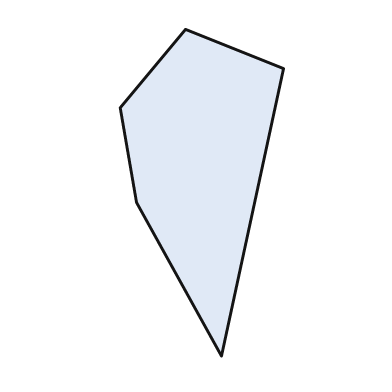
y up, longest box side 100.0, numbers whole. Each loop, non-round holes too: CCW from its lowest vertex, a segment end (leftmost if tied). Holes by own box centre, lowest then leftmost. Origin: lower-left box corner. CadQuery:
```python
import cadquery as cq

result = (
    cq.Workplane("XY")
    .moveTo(31.0, 0.0)
    .lineTo(50.0, 88.0)
    .lineTo(20.0, 100.0)
    .lineTo(0.0, 76.0)
    .lineTo(5.0, 47.0)
    .close()
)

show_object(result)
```